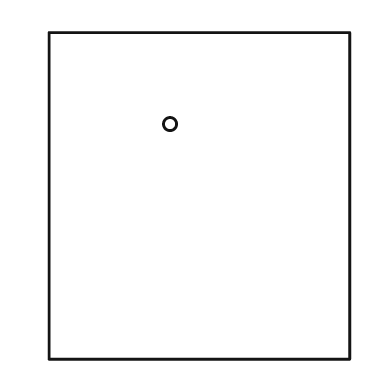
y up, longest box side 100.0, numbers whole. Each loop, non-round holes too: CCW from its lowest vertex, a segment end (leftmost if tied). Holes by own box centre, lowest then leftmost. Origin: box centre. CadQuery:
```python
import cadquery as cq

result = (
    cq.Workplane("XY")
    .moveTo(-46.0, -50.0)
    .lineTo(46.0, -50.0)
    .lineTo(46.0, 50.0)
    .lineTo(-46.0, 50.0)
    .close()
    .moveTo(-9.0, 22.0)
    .circle(2.0)
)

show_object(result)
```